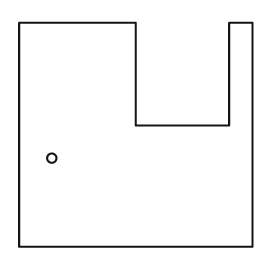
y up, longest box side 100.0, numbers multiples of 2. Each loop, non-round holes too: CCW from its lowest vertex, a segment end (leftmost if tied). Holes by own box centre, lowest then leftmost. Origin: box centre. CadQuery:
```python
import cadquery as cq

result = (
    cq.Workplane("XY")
    .moveTo(-50.0, -48.0)
    .lineTo(50.0, -48.0)
    .lineTo(50.0, 48.0)
    .lineTo(40.0, 48.0)
    .lineTo(40.0, 4.0)
    .lineTo(0.0, 4.0)
    .lineTo(0.0, 48.0)
    .lineTo(-50.0, 48.0)
    .close()
    .moveTo(-36.0, -10.0)
    .circle(2.0)
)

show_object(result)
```